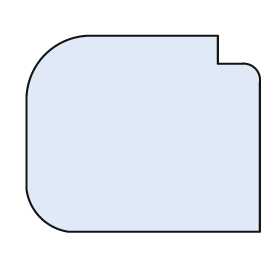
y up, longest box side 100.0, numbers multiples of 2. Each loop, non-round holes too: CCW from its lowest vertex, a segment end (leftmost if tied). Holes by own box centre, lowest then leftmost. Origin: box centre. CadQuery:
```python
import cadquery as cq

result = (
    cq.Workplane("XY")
    .moveTo(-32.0, -42.0)
    .lineTo(50.0, -42.0)
    .lineTo(50.0, 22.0)
    .threePointArc((48.0, 28.0), (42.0, 30.0))
    .lineTo(32.0, 30.0)
    .lineTo(32.0, 42.0)
    .lineTo(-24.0, 42.0)
    .threePointArc((-42.0, 34.0), (-50.0, 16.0))
    .lineTo(-50.0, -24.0)
    .threePointArc((-44.0, -36.0), (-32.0, -42.0))
    .close()
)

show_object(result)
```